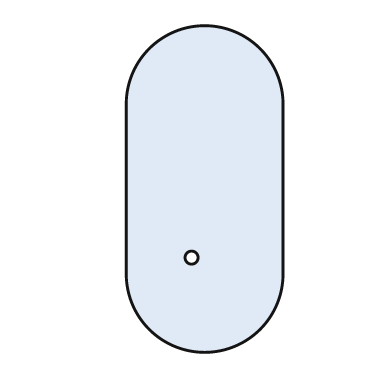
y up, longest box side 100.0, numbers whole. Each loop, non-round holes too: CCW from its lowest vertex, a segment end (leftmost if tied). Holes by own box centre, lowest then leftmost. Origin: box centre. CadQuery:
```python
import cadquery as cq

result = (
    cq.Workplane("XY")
    .moveTo(-24.0, -26.0)
    .threePointArc((0.0, -50.0), (24.0, -26.0))
    .lineTo(24.0, 26.0)
    .threePointArc((0.0, 50.0), (-24.0, 26.0))
    .close()
    .moveTo(-4.0, -21.0)
    .circle(2.0)
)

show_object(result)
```